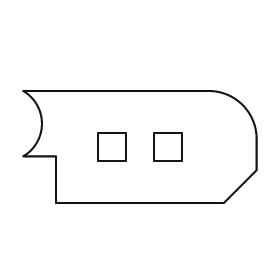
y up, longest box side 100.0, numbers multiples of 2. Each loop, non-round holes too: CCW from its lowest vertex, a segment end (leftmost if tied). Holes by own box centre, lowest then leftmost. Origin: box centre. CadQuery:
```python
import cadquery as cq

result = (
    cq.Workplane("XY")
    .moveTo(-36.0, -24.0)
    .lineTo(36.0, -24.0)
    .lineTo(50.0, -10.0)
    .lineTo(50.0, 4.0)
    .threePointArc((44.0, 18.0), (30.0, 24.0))
    .lineTo(-50.0, 24.0)
    .threePointArc((-42.0, 10.0), (-50.0, -4.0))
    .lineTo(-36.0, -4.0)
    .close()
    .moveTo(-18.0, -6.0)
    .lineTo(-6.0, -6.0)
    .lineTo(-6.0, 6.0)
    .lineTo(-18.0, 6.0)
    .close()
    .moveTo(6.0, -6.0)
    .lineTo(18.0, -6.0)
    .lineTo(18.0, 6.0)
    .lineTo(6.0, 6.0)
    .close()
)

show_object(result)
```